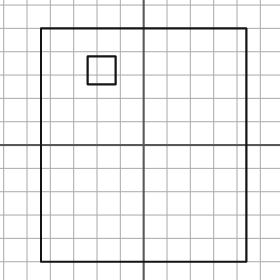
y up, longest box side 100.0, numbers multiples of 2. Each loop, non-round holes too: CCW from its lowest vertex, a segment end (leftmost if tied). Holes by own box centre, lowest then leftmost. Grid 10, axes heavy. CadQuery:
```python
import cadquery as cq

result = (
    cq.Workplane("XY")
    .moveTo(-44.0, -50.0)
    .lineTo(44.0, -50.0)
    .lineTo(44.0, 50.0)
    .lineTo(-44.0, 50.0)
    .close()
    .moveTo(-24.0, 26.0)
    .lineTo(-12.0, 26.0)
    .lineTo(-12.0, 38.0)
    .lineTo(-24.0, 38.0)
    .close()
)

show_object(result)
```